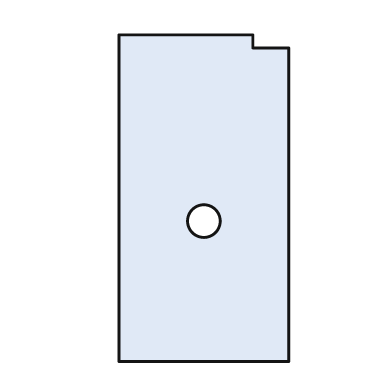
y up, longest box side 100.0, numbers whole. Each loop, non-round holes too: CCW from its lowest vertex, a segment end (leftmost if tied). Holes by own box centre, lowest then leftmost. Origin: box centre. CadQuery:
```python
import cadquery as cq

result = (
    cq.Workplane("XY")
    .moveTo(-26.0, -50.0)
    .lineTo(26.0, -50.0)
    .lineTo(26.0, 46.0)
    .lineTo(15.0, 46.0)
    .lineTo(15.0, 50.0)
    .lineTo(-26.0, 50.0)
    .close()
    .moveTo(0.0, -7.0)
    .circle(5.0)
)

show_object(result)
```